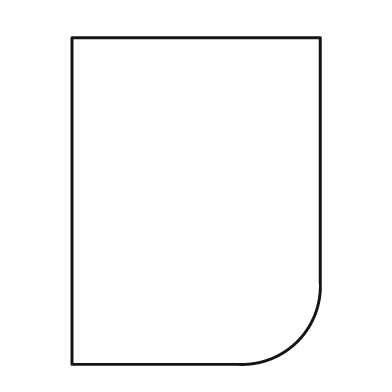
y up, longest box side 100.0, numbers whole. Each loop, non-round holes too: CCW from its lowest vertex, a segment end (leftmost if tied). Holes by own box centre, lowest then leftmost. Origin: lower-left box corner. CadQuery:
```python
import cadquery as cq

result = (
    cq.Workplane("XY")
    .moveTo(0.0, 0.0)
    .lineTo(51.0, 0.0)
    .threePointArc((69.0, 7.0), (76.0, 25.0))
    .lineTo(76.0, 100.0)
    .lineTo(0.0, 100.0)
    .close()
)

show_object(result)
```